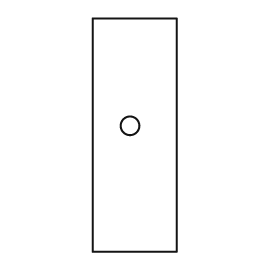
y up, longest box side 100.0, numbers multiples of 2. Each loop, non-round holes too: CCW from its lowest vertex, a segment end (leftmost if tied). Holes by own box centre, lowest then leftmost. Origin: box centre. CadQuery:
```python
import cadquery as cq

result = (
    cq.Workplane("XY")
    .moveTo(-18.0, -50.0)
    .lineTo(18.0, -50.0)
    .lineTo(18.0, 50.0)
    .lineTo(-18.0, 50.0)
    .close()
    .moveTo(-2.0, 4.0)
    .circle(4.0)
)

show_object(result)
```